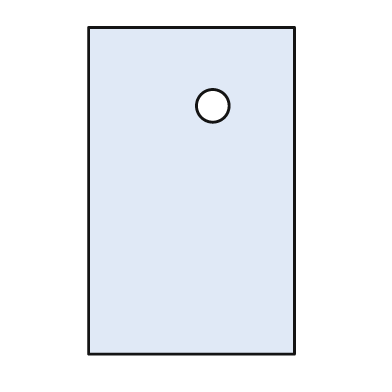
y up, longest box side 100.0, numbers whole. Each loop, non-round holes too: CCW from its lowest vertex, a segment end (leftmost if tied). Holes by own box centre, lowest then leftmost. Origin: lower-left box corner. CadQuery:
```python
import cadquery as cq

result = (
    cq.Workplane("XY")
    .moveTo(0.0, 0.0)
    .lineTo(63.0, 0.0)
    .lineTo(63.0, 100.0)
    .lineTo(0.0, 100.0)
    .close()
    .moveTo(38.0, 76.0)
    .circle(5.0)
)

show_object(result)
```